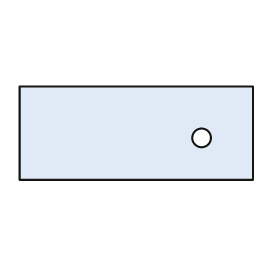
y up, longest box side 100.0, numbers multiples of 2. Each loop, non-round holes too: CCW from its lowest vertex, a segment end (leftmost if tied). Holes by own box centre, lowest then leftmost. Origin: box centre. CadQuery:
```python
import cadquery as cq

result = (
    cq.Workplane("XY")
    .moveTo(-50.0, -20.0)
    .lineTo(50.0, -20.0)
    .lineTo(50.0, 20.0)
    .lineTo(-50.0, 20.0)
    .close()
    .moveTo(28.0, -2.0)
    .circle(4.0)
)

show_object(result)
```